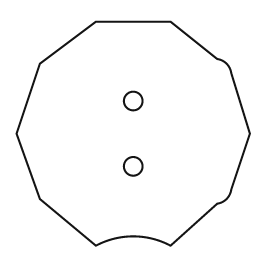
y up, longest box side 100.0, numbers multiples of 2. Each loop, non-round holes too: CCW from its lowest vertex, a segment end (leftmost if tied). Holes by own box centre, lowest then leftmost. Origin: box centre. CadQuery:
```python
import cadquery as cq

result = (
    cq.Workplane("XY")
    .moveTo(-16.0, -48.0)
    .threePointArc((0.0, -44.0), (16.0, -48.0))
    .lineTo(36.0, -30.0)
    .threePointArc((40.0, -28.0), (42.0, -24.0))
    .lineTo(50.0, 0.0)
    .lineTo(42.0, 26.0)
    .threePointArc((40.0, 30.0), (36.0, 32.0))
    .lineTo(16.0, 48.0)
    .lineTo(-16.0, 48.0)
    .lineTo(-40.0, 30.0)
    .lineTo(-50.0, 0.0)
    .lineTo(-40.0, -28.0)
    .close()
    .moveTo(0.0, -14.0)
    .circle(4.0)
    .moveTo(0.0, 14.0)
    .circle(4.0)
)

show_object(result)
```